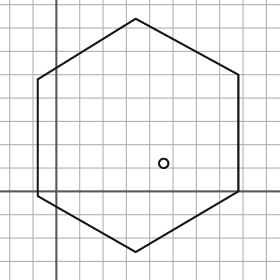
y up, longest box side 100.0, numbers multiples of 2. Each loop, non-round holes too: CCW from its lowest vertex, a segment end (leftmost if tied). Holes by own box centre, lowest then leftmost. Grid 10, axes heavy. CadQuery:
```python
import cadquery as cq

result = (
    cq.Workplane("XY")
    .moveTo(34.0, -26.0)
    .lineTo(78.0, 0.0)
    .lineTo(78.0, 50.0)
    .lineTo(34.0, 74.0)
    .lineTo(-8.0, 48.0)
    .lineTo(-8.0, -2.0)
    .close()
    .moveTo(46.0, 12.0)
    .circle(2.0)
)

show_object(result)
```